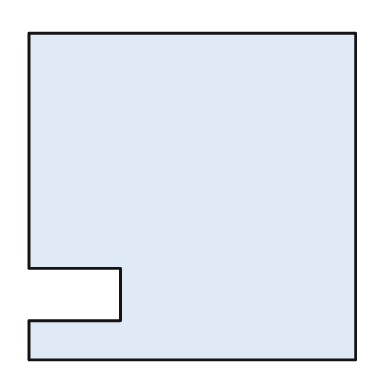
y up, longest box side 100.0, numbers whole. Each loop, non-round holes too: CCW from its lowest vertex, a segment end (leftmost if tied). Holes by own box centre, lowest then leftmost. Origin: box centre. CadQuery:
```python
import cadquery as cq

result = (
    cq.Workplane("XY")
    .moveTo(-50.0, -50.0)
    .lineTo(50.0, -50.0)
    .lineTo(50.0, 50.0)
    .lineTo(-50.0, 50.0)
    .lineTo(-50.0, -22.0)
    .lineTo(-22.0, -22.0)
    .lineTo(-22.0, -38.0)
    .lineTo(-50.0, -38.0)
    .close()
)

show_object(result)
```